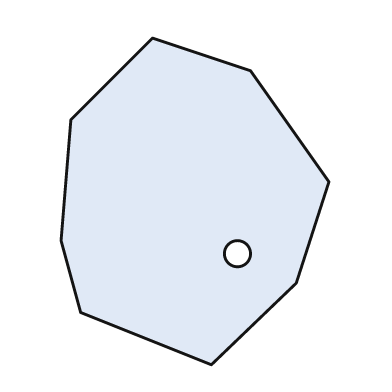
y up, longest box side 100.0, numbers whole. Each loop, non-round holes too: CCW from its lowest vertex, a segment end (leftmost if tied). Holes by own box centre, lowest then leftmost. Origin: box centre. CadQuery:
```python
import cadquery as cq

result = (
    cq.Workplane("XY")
    .moveTo(5.0, -50.0)
    .lineTo(31.0, -25.0)
    .lineTo(41.0, 6.0)
    .lineTo(17.0, 40.0)
    .lineTo(-13.0, 50.0)
    .lineTo(-38.0, 25.0)
    .lineTo(-41.0, -12.0)
    .lineTo(-35.0, -34.0)
    .close()
    .moveTo(13.0, -16.0)
    .circle(4.0)
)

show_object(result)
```